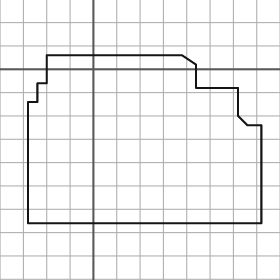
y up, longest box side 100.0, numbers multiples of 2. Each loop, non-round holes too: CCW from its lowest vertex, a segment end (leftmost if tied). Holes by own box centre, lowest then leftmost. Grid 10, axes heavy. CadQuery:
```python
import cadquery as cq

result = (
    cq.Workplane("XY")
    .moveTo(-28.0, -66.0)
    .lineTo(72.0, -66.0)
    .lineTo(72.0, -24.0)
    .lineTo(66.0, -24.0)
    .lineTo(62.0, -20.0)
    .lineTo(62.0, -8.0)
    .lineTo(44.0, -8.0)
    .lineTo(44.0, 2.0)
    .lineTo(38.0, 6.0)
    .lineTo(-20.0, 6.0)
    .lineTo(-20.0, -6.0)
    .lineTo(-24.0, -6.0)
    .lineTo(-24.0, -14.0)
    .lineTo(-28.0, -14.0)
    .close()
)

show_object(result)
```